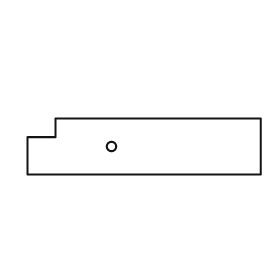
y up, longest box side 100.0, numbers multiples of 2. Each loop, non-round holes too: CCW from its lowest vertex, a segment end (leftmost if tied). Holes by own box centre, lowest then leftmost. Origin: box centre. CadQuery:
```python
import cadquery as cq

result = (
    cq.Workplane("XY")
    .moveTo(-50.0, -12.0)
    .lineTo(50.0, -12.0)
    .lineTo(50.0, 12.0)
    .lineTo(-38.0, 12.0)
    .lineTo(-38.0, 4.0)
    .lineTo(-50.0, 4.0)
    .close()
    .moveTo(-14.0, 0.0)
    .circle(2.0)
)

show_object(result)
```